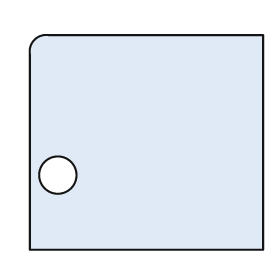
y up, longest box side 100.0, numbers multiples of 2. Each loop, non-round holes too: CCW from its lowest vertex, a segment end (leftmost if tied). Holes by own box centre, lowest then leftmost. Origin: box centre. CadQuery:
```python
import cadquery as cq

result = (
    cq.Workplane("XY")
    .moveTo(-50.0, -46.0)
    .lineTo(50.0, -46.0)
    .lineTo(50.0, 46.0)
    .lineTo(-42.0, 46.0)
    .threePointArc((-48.0, 44.0), (-50.0, 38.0))
    .close()
    .moveTo(-38.0, -14.0)
    .circle(8.0)
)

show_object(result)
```